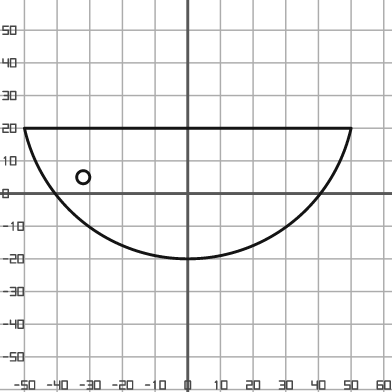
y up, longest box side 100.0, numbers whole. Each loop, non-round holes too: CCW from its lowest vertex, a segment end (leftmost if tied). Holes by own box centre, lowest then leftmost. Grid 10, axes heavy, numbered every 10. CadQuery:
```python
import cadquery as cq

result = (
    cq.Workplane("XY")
    .moveTo(-50.0, 20.0)
    .threePointArc((0.0, -20.0), (50.0, 20.0))
    .close()
    .moveTo(-32.0, 5.0)
    .circle(2.0)
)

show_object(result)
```